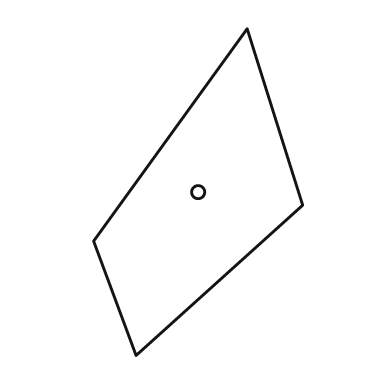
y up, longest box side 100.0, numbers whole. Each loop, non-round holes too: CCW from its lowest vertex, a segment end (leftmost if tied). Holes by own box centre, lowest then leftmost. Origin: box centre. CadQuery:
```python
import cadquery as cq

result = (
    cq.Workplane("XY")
    .moveTo(-19.0, -50.0)
    .lineTo(32.0, -4.0)
    .lineTo(15.0, 50.0)
    .lineTo(-32.0, -15.0)
    .close()
    .moveTo(0.0, 0.0)
    .circle(2.0)
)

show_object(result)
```